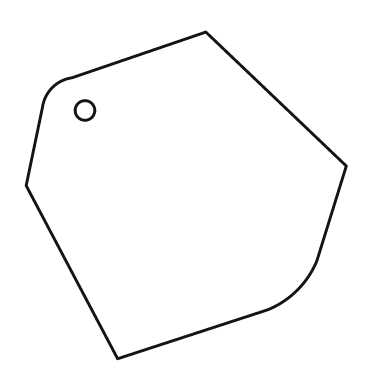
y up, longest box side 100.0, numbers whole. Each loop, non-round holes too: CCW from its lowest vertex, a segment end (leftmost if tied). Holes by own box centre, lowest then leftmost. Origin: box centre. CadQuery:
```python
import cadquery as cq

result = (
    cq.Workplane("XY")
    .moveTo(-21.0, -50.0)
    .lineTo(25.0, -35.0)
    .threePointArc((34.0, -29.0), (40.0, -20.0))
    .lineTo(49.0, 9.0)
    .lineTo(6.0, 50.0)
    .lineTo(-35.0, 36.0)
    .threePointArc((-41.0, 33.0), (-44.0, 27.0))
    .lineTo(-49.0, 3.0)
    .close()
    .moveTo(-31.0, 26.0)
    .circle(3.0)
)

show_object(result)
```